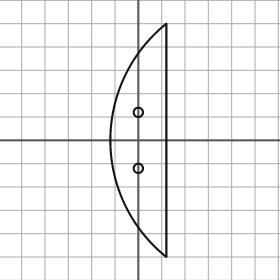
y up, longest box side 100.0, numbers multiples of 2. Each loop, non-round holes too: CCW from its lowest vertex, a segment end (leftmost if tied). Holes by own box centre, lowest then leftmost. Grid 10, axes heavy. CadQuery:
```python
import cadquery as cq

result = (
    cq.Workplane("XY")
    .moveTo(12.0, -50.0)
    .lineTo(12.0, 50.0)
    .threePointArc((-12.0, 0.0), (12.0, -50.0))
    .close()
    .moveTo(0.0, -12.0)
    .circle(2.0)
    .moveTo(0.0, 12.0)
    .circle(2.0)
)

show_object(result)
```